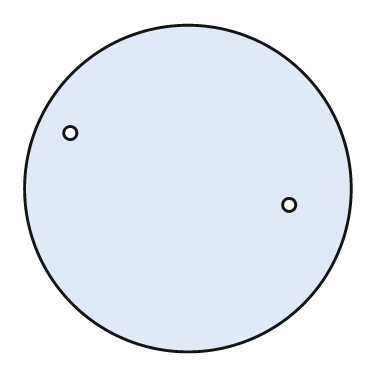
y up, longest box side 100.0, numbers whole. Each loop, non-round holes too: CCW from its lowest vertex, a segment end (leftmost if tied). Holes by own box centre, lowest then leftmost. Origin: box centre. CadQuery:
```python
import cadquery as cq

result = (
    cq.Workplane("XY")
    .moveTo(0.0, 0.0)
    .circle(50.0)
    .moveTo(31.0, -5.0)
    .circle(2.0)
    .moveTo(-36.0, 17.0)
    .circle(2.0)
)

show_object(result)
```